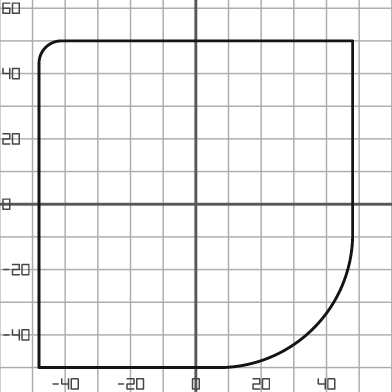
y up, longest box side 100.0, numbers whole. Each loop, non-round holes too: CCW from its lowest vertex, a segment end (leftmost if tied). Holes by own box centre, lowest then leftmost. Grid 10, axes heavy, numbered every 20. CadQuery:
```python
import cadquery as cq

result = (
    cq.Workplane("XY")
    .moveTo(-48.0, -50.0)
    .lineTo(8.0, -50.0)
    .threePointArc((36.0, -38.0), (48.0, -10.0))
    .lineTo(48.0, 50.0)
    .lineTo(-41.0, 50.0)
    .threePointArc((-46.0, 48.0), (-48.0, 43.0))
    .close()
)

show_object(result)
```